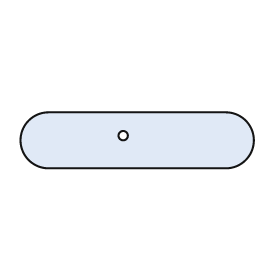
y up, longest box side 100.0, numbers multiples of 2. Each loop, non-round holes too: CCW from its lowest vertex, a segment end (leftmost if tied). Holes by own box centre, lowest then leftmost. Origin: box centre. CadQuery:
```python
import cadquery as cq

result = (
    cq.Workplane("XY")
    .moveTo(-38.0, -12.0)
    .lineTo(38.0, -12.0)
    .threePointArc((50.0, 0.0), (38.0, 12.0))
    .lineTo(-38.0, 12.0)
    .threePointArc((-50.0, 0.0), (-38.0, -12.0))
    .close()
    .moveTo(-6.0, 2.0)
    .circle(2.0)
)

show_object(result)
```